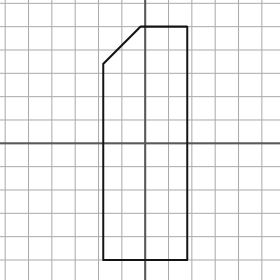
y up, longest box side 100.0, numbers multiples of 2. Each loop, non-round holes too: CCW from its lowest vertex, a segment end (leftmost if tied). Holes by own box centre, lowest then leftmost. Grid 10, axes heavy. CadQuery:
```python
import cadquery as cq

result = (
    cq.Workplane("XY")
    .moveTo(-18.0, -50.0)
    .lineTo(18.0, -50.0)
    .lineTo(18.0, 50.0)
    .lineTo(-2.0, 50.0)
    .lineTo(-18.0, 34.0)
    .close()
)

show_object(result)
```